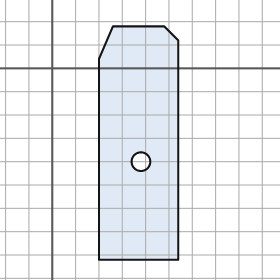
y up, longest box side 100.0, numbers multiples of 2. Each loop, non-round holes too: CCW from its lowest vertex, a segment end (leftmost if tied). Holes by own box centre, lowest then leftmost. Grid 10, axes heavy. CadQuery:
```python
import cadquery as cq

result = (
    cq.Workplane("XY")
    .moveTo(20.0, -82.0)
    .lineTo(54.0, -82.0)
    .lineTo(54.0, 12.0)
    .lineTo(48.0, 18.0)
    .lineTo(26.0, 18.0)
    .lineTo(20.0, 4.0)
    .close()
    .moveTo(38.0, -40.0)
    .circle(4.0)
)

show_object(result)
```